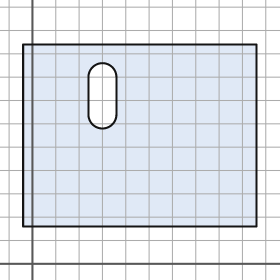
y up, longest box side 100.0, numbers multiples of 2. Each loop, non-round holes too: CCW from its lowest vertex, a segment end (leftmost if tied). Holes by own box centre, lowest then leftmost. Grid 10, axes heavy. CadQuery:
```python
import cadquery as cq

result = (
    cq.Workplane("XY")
    .moveTo(-4.0, 16.0)
    .lineTo(96.0, 16.0)
    .lineTo(96.0, 94.0)
    .lineTo(-4.0, 94.0)
    .close()
    .moveTo(24.0, 64.0)
    .threePointArc((30.0, 58.0), (36.0, 64.0))
    .lineTo(36.0, 80.0)
    .threePointArc((30.0, 86.0), (24.0, 80.0))
    .close()
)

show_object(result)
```